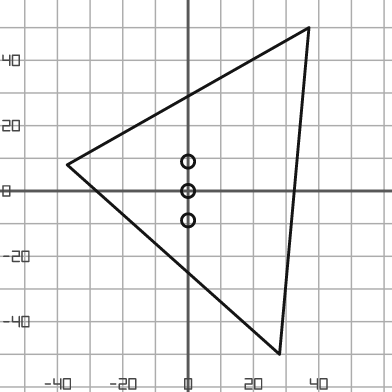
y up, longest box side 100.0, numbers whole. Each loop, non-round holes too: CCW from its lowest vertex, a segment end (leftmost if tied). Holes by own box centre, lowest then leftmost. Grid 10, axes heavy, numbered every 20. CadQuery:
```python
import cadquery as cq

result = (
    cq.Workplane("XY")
    .moveTo(28.0, -50.0)
    .lineTo(37.0, 50.0)
    .lineTo(-37.0, 8.0)
    .close()
    .moveTo(0.0, -9.0)
    .circle(2.0)
    .moveTo(0.0, 0.0)
    .circle(2.0)
    .moveTo(0.0, 9.0)
    .circle(2.0)
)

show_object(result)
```